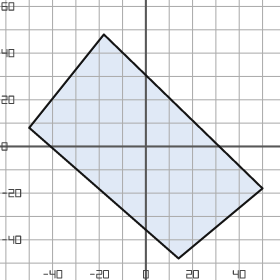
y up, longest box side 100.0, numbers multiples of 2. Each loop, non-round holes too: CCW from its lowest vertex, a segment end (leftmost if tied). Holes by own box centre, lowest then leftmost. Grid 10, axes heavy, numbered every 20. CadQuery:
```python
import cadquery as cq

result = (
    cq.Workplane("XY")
    .moveTo(14.0, -48.0)
    .lineTo(50.0, -18.0)
    .lineTo(-18.0, 48.0)
    .lineTo(-50.0, 8.0)
    .close()
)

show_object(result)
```